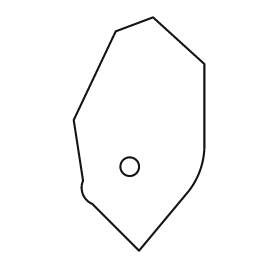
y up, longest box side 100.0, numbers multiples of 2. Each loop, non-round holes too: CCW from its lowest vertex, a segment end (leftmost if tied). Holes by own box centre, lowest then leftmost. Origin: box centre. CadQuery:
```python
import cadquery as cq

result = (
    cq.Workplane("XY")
    .moveTo(0.0, -50.0)
    .lineTo(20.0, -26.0)
    .threePointArc((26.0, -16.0), (28.0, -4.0))
    .lineTo(28.0, 30.0)
    .lineTo(6.0, 50.0)
    .lineTo(-10.0, 44.0)
    .lineTo(-28.0, 6.0)
    .lineTo(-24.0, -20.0)
    .threePointArc((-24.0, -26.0), (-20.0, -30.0))
    .close()
    .moveTo(-4.0, -14.0)
    .circle(4.0)
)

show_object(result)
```